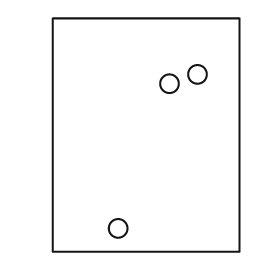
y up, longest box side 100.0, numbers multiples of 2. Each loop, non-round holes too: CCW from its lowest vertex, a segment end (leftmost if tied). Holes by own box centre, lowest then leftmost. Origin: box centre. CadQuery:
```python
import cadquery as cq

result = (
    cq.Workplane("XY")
    .moveTo(-40.0, -50.0)
    .lineTo(40.0, -50.0)
    .lineTo(40.0, 50.0)
    .lineTo(-40.0, 50.0)
    .close()
    .moveTo(-12.0, -40.0)
    .circle(4.0)
    .moveTo(10.0, 22.0)
    .circle(4.0)
    .moveTo(22.0, 26.0)
    .circle(4.0)
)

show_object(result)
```